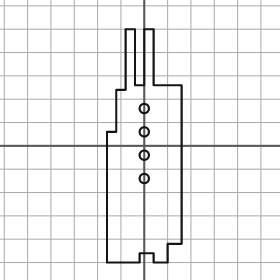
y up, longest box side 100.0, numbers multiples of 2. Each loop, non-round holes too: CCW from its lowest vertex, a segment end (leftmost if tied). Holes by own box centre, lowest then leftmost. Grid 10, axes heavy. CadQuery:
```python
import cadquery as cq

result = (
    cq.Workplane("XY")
    .moveTo(-16.0, -50.0)
    .lineTo(-2.0, -50.0)
    .lineTo(-2.0, -46.0)
    .lineTo(4.0, -46.0)
    .lineTo(4.0, -50.0)
    .lineTo(10.0, -50.0)
    .lineTo(10.0, -42.0)
    .lineTo(16.0, -42.0)
    .lineTo(16.0, 26.0)
    .lineTo(4.0, 26.0)
    .lineTo(4.0, 50.0)
    .lineTo(0.0, 50.0)
    .lineTo(0.0, 26.0)
    .lineTo(-4.0, 26.0)
    .lineTo(-4.0, 50.0)
    .lineTo(-8.0, 50.0)
    .lineTo(-8.0, 24.0)
    .lineTo(-12.0, 24.0)
    .lineTo(-12.0, 6.0)
    .lineTo(-16.0, 6.0)
    .close()
    .moveTo(0.0, -14.0)
    .circle(2.0)
    .moveTo(0.0, -4.0)
    .circle(2.0)
    .moveTo(0.0, 6.0)
    .circle(2.0)
    .moveTo(0.0, 16.0)
    .circle(2.0)
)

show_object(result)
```